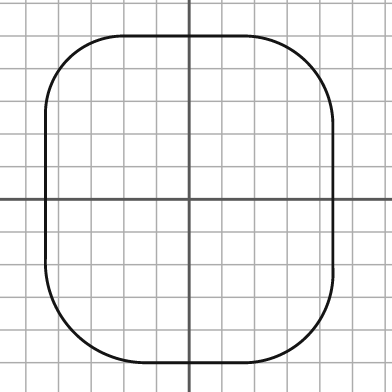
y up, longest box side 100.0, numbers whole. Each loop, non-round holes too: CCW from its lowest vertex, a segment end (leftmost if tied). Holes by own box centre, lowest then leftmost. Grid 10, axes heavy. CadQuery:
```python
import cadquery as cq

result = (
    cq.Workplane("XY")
    .moveTo(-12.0, -50.0)
    .lineTo(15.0, -50.0)
    .threePointArc((36.0, -42.0), (44.0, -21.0))
    .lineTo(44.0, 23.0)
    .threePointArc((36.0, 42.0), (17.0, 50.0))
    .lineTo(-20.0, 50.0)
    .threePointArc((-37.0, 43.0), (-44.0, 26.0))
    .lineTo(-44.0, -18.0)
    .threePointArc((-35.0, -41.0), (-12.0, -50.0))
    .close()
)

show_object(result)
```